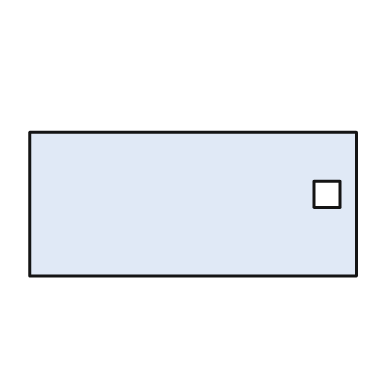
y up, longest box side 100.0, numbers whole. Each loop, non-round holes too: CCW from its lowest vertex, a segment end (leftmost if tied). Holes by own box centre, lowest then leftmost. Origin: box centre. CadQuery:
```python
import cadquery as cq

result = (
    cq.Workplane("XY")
    .moveTo(-50.0, -22.0)
    .lineTo(50.0, -22.0)
    .lineTo(50.0, 22.0)
    .lineTo(-50.0, 22.0)
    .close()
    .moveTo(37.0, -1.0)
    .lineTo(45.0, -1.0)
    .lineTo(45.0, 7.0)
    .lineTo(37.0, 7.0)
    .close()
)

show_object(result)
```